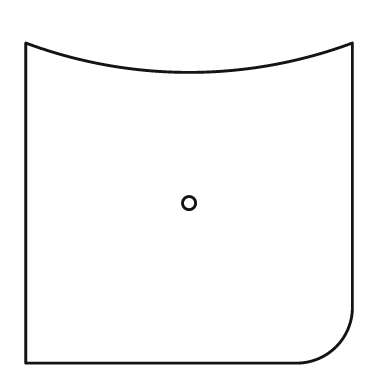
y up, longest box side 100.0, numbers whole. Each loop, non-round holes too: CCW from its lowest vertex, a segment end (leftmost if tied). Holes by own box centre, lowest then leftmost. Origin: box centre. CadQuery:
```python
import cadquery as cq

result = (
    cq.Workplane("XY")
    .moveTo(-50.0, -49.0)
    .lineTo(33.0, -49.0)
    .threePointArc((45.0, -44.0), (50.0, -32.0))
    .lineTo(50.0, 49.0)
    .threePointArc((0.0, 40.0), (-50.0, 49.0))
    .close()
    .moveTo(0.0, 0.0)
    .circle(2.0)
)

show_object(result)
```